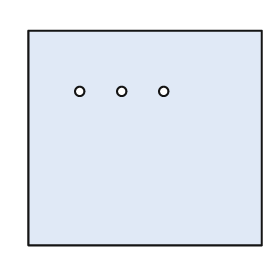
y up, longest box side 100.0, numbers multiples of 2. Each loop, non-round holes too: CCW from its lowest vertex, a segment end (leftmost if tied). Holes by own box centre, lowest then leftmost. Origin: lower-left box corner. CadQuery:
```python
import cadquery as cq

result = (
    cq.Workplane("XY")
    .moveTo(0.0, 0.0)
    .lineTo(100.0, 0.0)
    .lineTo(100.0, 92.0)
    .lineTo(0.0, 92.0)
    .close()
    .moveTo(22.0, 66.0)
    .circle(2.0)
    .moveTo(40.0, 66.0)
    .circle(2.0)
    .moveTo(58.0, 66.0)
    .circle(2.0)
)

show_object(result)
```